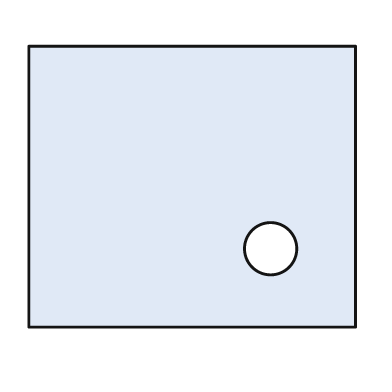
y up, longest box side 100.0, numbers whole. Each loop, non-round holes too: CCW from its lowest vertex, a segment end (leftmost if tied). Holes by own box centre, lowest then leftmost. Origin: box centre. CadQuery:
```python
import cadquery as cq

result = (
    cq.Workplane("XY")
    .moveTo(-50.0, -43.0)
    .lineTo(50.0, -43.0)
    .lineTo(50.0, 43.0)
    .lineTo(-50.0, 43.0)
    .close()
    .moveTo(24.0, -19.0)
    .circle(8.0)
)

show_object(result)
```